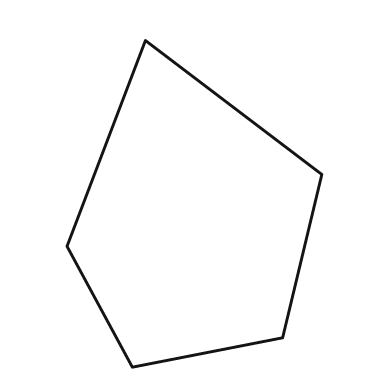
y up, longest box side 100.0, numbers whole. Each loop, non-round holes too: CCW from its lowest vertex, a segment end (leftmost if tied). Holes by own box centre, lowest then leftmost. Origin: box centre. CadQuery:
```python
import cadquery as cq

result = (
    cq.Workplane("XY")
    .moveTo(-19.0, -50.0)
    .lineTo(27.0, -41.0)
    .lineTo(39.0, 9.0)
    .lineTo(-15.0, 50.0)
    .lineTo(-39.0, -13.0)
    .close()
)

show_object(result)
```